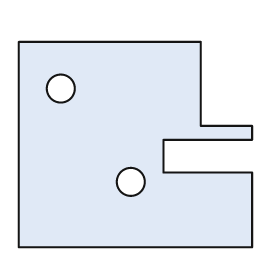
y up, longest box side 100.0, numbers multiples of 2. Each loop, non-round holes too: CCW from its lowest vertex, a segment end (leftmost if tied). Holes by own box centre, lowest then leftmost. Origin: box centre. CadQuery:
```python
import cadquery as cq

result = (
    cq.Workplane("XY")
    .moveTo(-50.0, -44.0)
    .lineTo(50.0, -44.0)
    .lineTo(50.0, -12.0)
    .lineTo(12.0, -12.0)
    .lineTo(12.0, 2.0)
    .lineTo(50.0, 2.0)
    .lineTo(50.0, 8.0)
    .lineTo(28.0, 8.0)
    .lineTo(28.0, 44.0)
    .lineTo(-50.0, 44.0)
    .close()
    .moveTo(-2.0, -16.0)
    .circle(6.0)
    .moveTo(-32.0, 24.0)
    .circle(6.0)
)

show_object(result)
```